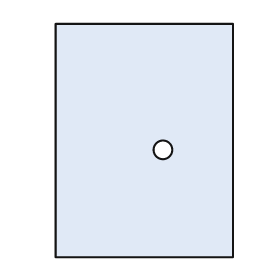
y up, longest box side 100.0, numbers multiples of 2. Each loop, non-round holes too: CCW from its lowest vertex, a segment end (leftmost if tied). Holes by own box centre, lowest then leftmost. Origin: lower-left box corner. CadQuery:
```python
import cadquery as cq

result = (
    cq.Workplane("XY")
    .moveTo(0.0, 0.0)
    .lineTo(76.0, 0.0)
    .lineTo(76.0, 100.0)
    .lineTo(0.0, 100.0)
    .close()
    .moveTo(46.0, 46.0)
    .circle(4.0)
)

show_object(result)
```